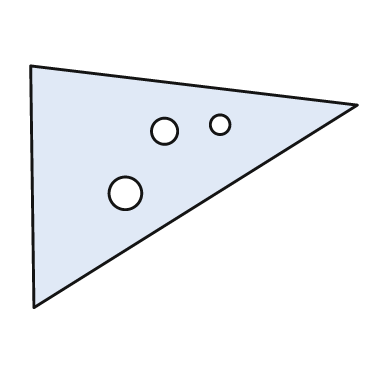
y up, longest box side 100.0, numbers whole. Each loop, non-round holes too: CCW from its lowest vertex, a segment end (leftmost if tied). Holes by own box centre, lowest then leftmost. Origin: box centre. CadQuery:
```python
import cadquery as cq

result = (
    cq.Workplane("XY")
    .moveTo(-49.0, -37.0)
    .lineTo(50.0, 25.0)
    .lineTo(-50.0, 37.0)
    .close()
    .moveTo(-21.0, -2.0)
    .circle(5.0)
    .moveTo(-9.0, 17.0)
    .circle(4.0)
    .moveTo(8.0, 19.0)
    .circle(3.0)
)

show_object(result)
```